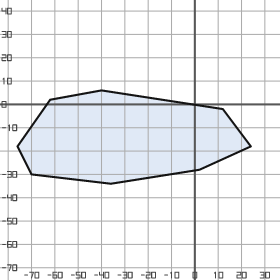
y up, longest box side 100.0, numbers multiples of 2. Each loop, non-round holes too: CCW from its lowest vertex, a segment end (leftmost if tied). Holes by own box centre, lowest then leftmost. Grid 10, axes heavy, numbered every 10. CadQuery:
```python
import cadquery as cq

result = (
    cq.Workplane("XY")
    .moveTo(-36.0, -34.0)
    .lineTo(2.0, -28.0)
    .lineTo(24.0, -18.0)
    .lineTo(12.0, -2.0)
    .lineTo(-40.0, 6.0)
    .lineTo(-62.0, 2.0)
    .lineTo(-76.0, -18.0)
    .lineTo(-70.0, -30.0)
    .close()
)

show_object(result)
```